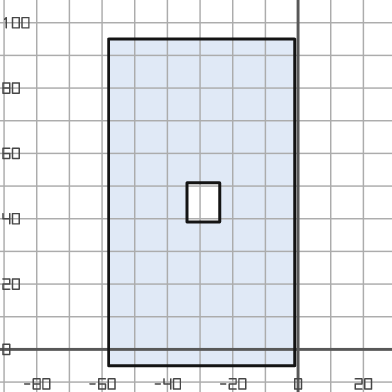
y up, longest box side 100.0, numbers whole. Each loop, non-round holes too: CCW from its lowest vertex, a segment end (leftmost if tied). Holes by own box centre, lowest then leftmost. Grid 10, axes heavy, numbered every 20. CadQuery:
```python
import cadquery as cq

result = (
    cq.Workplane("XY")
    .moveTo(-58.0, -5.0)
    .lineTo(-1.0, -5.0)
    .lineTo(-1.0, 95.0)
    .lineTo(-58.0, 95.0)
    .close()
    .moveTo(-34.0, 39.0)
    .lineTo(-24.0, 39.0)
    .lineTo(-24.0, 51.0)
    .lineTo(-34.0, 51.0)
    .close()
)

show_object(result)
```